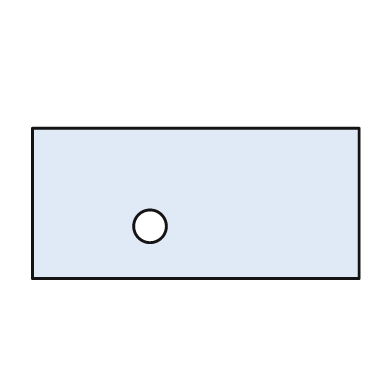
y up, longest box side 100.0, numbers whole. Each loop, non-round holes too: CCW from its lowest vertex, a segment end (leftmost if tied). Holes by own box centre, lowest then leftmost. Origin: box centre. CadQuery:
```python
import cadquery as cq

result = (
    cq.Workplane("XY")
    .moveTo(-50.0, -23.0)
    .lineTo(50.0, -23.0)
    .lineTo(50.0, 23.0)
    .lineTo(-50.0, 23.0)
    .close()
    .moveTo(-14.0, -7.0)
    .circle(5.0)
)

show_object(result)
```